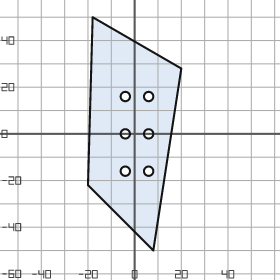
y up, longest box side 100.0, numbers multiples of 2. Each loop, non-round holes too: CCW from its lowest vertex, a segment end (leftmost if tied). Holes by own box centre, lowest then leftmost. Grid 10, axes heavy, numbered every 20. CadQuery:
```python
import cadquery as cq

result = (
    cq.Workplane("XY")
    .moveTo(8.0, -50.0)
    .lineTo(20.0, 28.0)
    .lineTo(-18.0, 50.0)
    .lineTo(-20.0, -22.0)
    .close()
    .moveTo(-4.0, -16.0)
    .circle(2.0)
    .moveTo(6.0, -16.0)
    .circle(2.0)
    .moveTo(-4.0, 0.0)
    .circle(2.0)
    .moveTo(6.0, 0.0)
    .circle(2.0)
    .moveTo(-4.0, 16.0)
    .circle(2.0)
    .moveTo(6.0, 16.0)
    .circle(2.0)
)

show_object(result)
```